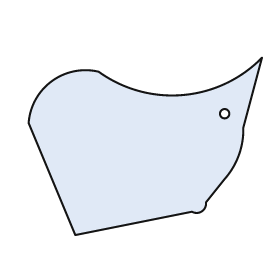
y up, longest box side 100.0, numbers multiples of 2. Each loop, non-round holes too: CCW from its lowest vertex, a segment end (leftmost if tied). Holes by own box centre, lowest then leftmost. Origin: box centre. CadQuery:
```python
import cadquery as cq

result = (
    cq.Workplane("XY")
    .moveTo(-30.0, -38.0)
    .lineTo(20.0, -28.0)
    .threePointArc((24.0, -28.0), (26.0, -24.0))
    .lineTo(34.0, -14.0)
    .threePointArc((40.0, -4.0), (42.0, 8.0))
    .lineTo(50.0, 38.0)
    .threePointArc((16.0, 22.0), (-20.0, 32.0))
    .threePointArc((-40.0, 28.0), (-50.0, 10.0))
    .close()
    .moveTo(34.0, 14.0)
    .circle(2.0)
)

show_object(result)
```